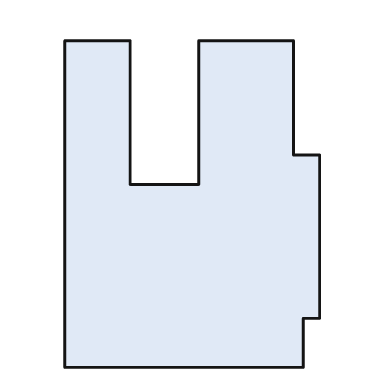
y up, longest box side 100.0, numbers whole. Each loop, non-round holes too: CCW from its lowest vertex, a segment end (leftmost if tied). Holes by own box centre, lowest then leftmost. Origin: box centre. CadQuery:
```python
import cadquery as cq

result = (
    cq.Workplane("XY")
    .moveTo(-39.0, -50.0)
    .lineTo(34.0, -50.0)
    .lineTo(34.0, -35.0)
    .lineTo(39.0, -35.0)
    .lineTo(39.0, 15.0)
    .lineTo(31.0, 15.0)
    .lineTo(31.0, 50.0)
    .lineTo(2.0, 50.0)
    .lineTo(2.0, 6.0)
    .lineTo(-19.0, 6.0)
    .lineTo(-19.0, 50.0)
    .lineTo(-39.0, 50.0)
    .close()
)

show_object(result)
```